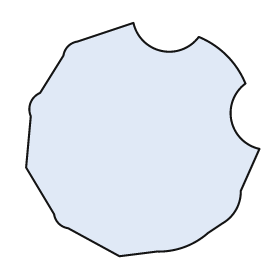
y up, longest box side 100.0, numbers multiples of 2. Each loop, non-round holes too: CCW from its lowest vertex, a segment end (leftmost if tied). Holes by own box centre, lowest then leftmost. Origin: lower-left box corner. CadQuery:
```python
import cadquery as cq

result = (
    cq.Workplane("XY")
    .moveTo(40.0, 0.0)
    .lineTo(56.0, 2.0)
    .threePointArc((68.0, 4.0), (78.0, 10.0))
    .lineTo(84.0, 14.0)
    .threePointArc((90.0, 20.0), (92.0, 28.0))
    .lineTo(100.0, 46.0)
    .threePointArc((88.0, 58.0), (94.0, 74.0))
    .threePointArc((86.0, 86.0), (74.0, 94.0))
    .threePointArc((58.0, 88.0), (46.0, 100.0))
    .lineTo(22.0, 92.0)
    .threePointArc((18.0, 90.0), (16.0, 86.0))
    .lineTo(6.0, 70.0)
    .threePointArc((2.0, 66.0), (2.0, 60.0))
    .lineTo(0.0, 38.0)
    .lineTo(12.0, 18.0)
    .threePointArc((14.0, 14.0), (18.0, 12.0))
    .close()
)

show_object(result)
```